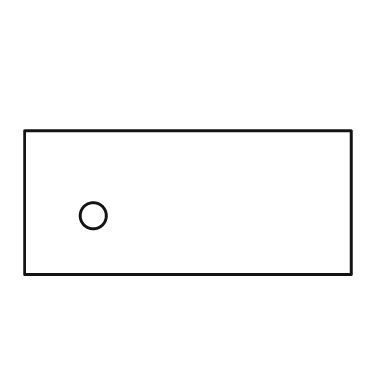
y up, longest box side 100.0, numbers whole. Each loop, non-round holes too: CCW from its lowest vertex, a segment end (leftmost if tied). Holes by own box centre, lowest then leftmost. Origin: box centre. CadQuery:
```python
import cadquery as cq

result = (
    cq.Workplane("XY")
    .moveTo(-50.0, -22.0)
    .lineTo(50.0, -22.0)
    .lineTo(50.0, 22.0)
    .lineTo(-50.0, 22.0)
    .close()
    .moveTo(-29.0, -4.0)
    .circle(4.0)
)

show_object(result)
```